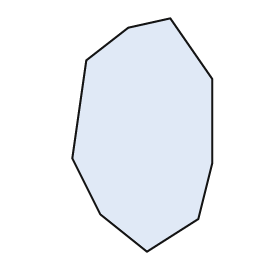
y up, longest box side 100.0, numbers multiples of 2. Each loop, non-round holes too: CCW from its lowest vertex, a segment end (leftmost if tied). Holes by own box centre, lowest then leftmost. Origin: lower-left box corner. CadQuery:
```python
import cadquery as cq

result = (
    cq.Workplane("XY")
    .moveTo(32.0, 0.0)
    .lineTo(54.0, 14.0)
    .lineTo(60.0, 38.0)
    .lineTo(60.0, 74.0)
    .lineTo(42.0, 100.0)
    .lineTo(24.0, 96.0)
    .lineTo(6.0, 82.0)
    .lineTo(0.0, 40.0)
    .lineTo(12.0, 16.0)
    .close()
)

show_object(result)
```